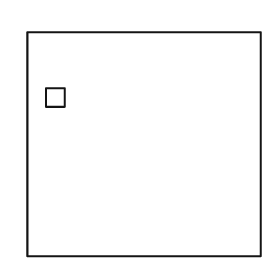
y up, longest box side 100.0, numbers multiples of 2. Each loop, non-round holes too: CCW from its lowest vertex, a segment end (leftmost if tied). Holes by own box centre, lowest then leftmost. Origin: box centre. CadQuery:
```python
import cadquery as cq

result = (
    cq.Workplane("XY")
    .moveTo(-50.0, -48.0)
    .lineTo(50.0, -48.0)
    .lineTo(50.0, 48.0)
    .lineTo(-50.0, 48.0)
    .close()
    .moveTo(-42.0, 16.0)
    .lineTo(-34.0, 16.0)
    .lineTo(-34.0, 24.0)
    .lineTo(-42.0, 24.0)
    .close()
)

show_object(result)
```